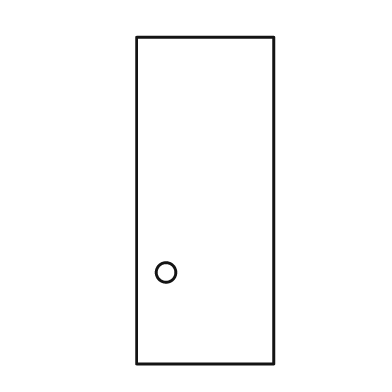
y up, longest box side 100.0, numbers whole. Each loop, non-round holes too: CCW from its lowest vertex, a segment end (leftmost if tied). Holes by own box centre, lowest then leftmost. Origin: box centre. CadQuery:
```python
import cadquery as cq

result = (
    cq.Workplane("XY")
    .moveTo(-21.0, -50.0)
    .lineTo(21.0, -50.0)
    .lineTo(21.0, 50.0)
    .lineTo(-21.0, 50.0)
    .close()
    .moveTo(-12.0, -22.0)
    .circle(3.0)
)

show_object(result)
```